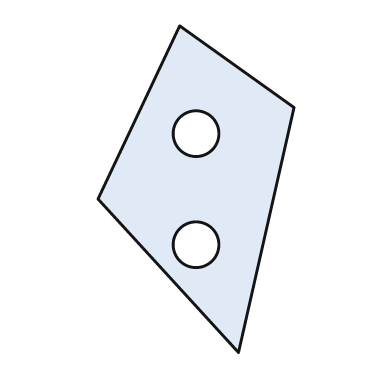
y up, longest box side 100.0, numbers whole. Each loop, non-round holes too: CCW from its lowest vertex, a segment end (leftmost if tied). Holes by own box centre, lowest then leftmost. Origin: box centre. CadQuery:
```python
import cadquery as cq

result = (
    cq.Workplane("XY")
    .moveTo(13.0, -50.0)
    .lineTo(30.0, 25.0)
    .lineTo(-5.0, 50.0)
    .lineTo(-30.0, -3.0)
    .close()
    .moveTo(0.0, -17.0)
    .circle(7.0)
    .moveTo(0.0, 17.0)
    .circle(7.0)
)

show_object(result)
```